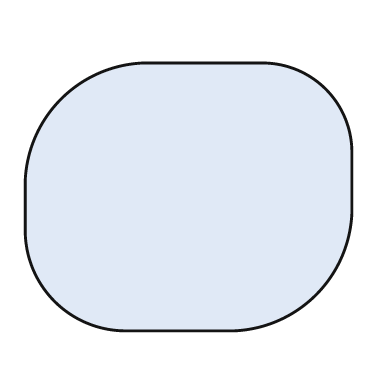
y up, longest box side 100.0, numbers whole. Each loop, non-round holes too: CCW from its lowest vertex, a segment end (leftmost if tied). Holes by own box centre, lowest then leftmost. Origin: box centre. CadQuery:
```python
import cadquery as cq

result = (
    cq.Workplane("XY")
    .moveTo(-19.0, -41.0)
    .lineTo(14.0, -41.0)
    .threePointArc((39.0, -30.0), (50.0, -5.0))
    .lineTo(50.0, 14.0)
    .threePointArc((42.0, 33.0), (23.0, 41.0))
    .lineTo(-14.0, 41.0)
    .threePointArc((-39.0, 30.0), (-50.0, 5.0))
    .lineTo(-50.0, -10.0)
    .threePointArc((-41.0, -32.0), (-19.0, -41.0))
    .close()
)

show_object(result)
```